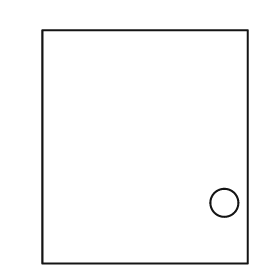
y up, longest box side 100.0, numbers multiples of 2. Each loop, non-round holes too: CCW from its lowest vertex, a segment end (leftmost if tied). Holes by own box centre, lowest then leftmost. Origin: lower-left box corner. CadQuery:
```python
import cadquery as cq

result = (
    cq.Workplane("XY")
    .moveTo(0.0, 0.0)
    .lineTo(88.0, 0.0)
    .lineTo(88.0, 100.0)
    .lineTo(0.0, 100.0)
    .close()
    .moveTo(78.0, 26.0)
    .circle(6.0)
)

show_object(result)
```